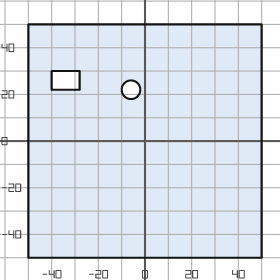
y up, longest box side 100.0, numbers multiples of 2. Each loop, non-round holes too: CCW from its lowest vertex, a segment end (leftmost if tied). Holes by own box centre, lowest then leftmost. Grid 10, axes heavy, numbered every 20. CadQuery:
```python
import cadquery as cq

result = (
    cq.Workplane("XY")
    .moveTo(-50.0, -50.0)
    .lineTo(50.0, -50.0)
    .lineTo(50.0, 50.0)
    .lineTo(-50.0, 50.0)
    .close()
    .moveTo(-6.0, 22.0)
    .circle(4.0)
    .moveTo(-40.0, 22.0)
    .lineTo(-28.0, 22.0)
    .lineTo(-28.0, 30.0)
    .lineTo(-40.0, 30.0)
    .close()
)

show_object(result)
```